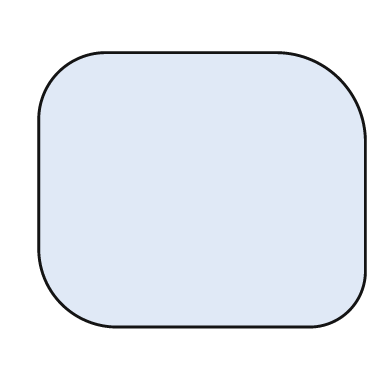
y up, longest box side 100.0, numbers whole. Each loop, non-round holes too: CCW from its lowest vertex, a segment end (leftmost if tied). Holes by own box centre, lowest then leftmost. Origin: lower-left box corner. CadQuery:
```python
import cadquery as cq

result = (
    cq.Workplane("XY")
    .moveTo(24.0, 0.0)
    .lineTo(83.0, 0.0)
    .threePointArc((95.0, 5.0), (100.0, 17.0))
    .lineTo(100.0, 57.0)
    .threePointArc((92.0, 76.0), (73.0, 84.0))
    .lineTo(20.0, 84.0)
    .threePointArc((6.0, 78.0), (0.0, 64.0))
    .lineTo(0.0, 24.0)
    .threePointArc((7.0, 7.0), (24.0, 0.0))
    .close()
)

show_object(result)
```